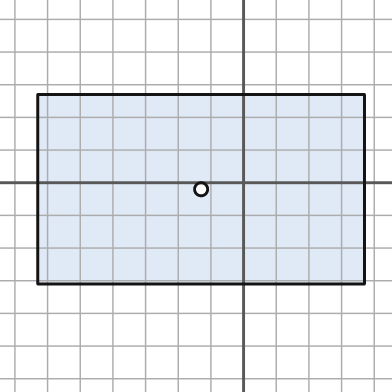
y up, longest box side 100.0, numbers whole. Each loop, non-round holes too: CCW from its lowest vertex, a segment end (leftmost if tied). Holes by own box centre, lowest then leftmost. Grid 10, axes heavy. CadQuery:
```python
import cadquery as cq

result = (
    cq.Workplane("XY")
    .moveTo(-63.0, -31.0)
    .lineTo(37.0, -31.0)
    .lineTo(37.0, 27.0)
    .lineTo(-63.0, 27.0)
    .close()
    .moveTo(-13.0, -2.0)
    .circle(2.0)
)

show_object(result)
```